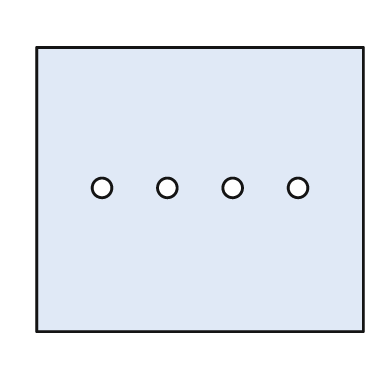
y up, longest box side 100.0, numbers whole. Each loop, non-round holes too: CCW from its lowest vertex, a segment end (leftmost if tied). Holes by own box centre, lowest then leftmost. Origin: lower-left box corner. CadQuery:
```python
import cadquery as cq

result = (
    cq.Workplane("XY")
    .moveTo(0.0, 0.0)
    .lineTo(100.0, 0.0)
    .lineTo(100.0, 87.0)
    .lineTo(0.0, 87.0)
    .close()
    .moveTo(20.0, 44.0)
    .circle(3.0)
    .moveTo(40.0, 44.0)
    .circle(3.0)
    .moveTo(60.0, 44.0)
    .circle(3.0)
    .moveTo(80.0, 44.0)
    .circle(3.0)
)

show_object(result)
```